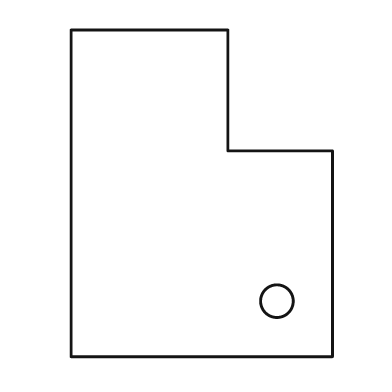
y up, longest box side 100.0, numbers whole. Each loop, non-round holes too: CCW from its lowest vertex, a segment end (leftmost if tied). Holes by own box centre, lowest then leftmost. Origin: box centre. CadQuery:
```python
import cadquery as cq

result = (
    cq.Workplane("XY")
    .moveTo(-40.0, -50.0)
    .lineTo(40.0, -50.0)
    .lineTo(40.0, 13.0)
    .lineTo(8.0, 13.0)
    .lineTo(8.0, 50.0)
    .lineTo(-40.0, 50.0)
    .close()
    .moveTo(23.0, -33.0)
    .circle(5.0)
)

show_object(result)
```